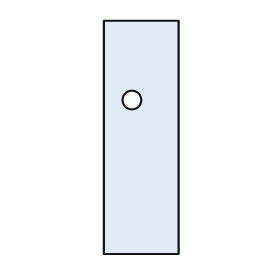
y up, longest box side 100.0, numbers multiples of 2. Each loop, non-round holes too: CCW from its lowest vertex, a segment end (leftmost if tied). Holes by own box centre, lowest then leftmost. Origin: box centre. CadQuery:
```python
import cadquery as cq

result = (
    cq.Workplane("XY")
    .moveTo(-16.0, -50.0)
    .lineTo(16.0, -50.0)
    .lineTo(16.0, 50.0)
    .lineTo(-16.0, 50.0)
    .close()
    .moveTo(-4.0, 16.0)
    .circle(4.0)
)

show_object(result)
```